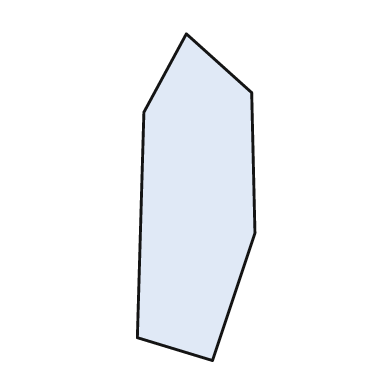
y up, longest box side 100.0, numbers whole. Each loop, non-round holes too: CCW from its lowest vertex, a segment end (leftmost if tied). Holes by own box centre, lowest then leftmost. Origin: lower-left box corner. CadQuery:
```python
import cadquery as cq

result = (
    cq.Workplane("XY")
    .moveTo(23.0, 0.0)
    .lineTo(36.0, 39.0)
    .lineTo(35.0, 82.0)
    .lineTo(15.0, 100.0)
    .lineTo(2.0, 76.0)
    .lineTo(0.0, 7.0)
    .close()
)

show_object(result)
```